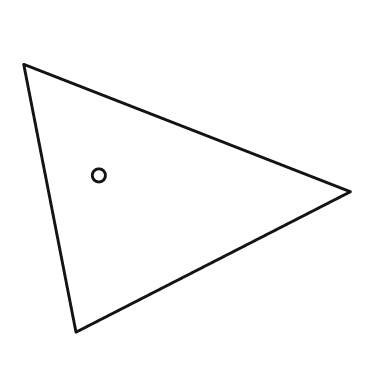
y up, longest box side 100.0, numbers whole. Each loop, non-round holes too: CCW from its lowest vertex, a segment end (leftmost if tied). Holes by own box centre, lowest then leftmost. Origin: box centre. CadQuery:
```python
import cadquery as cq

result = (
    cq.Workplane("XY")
    .moveTo(-34.0, -41.0)
    .lineTo(50.0, 2.0)
    .lineTo(-50.0, 41.0)
    .close()
    .moveTo(-27.0, 7.0)
    .circle(2.0)
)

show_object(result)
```